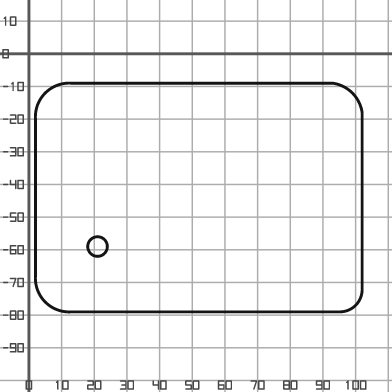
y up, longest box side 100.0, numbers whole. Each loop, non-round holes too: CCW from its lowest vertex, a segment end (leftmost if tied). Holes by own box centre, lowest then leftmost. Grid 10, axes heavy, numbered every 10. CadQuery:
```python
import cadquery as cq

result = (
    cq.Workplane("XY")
    .moveTo(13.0, -79.0)
    .lineTo(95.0, -79.0)
    .threePointArc((100.0, -77.0), (102.0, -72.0))
    .lineTo(102.0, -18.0)
    .threePointArc((99.0, -12.0), (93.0, -9.0))
    .lineTo(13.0, -9.0)
    .threePointArc((5.0, -12.0), (2.0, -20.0))
    .lineTo(2.0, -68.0)
    .threePointArc((5.0, -76.0), (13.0, -79.0))
    .close()
    .moveTo(21.0, -59.0)
    .circle(3.0)
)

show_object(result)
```